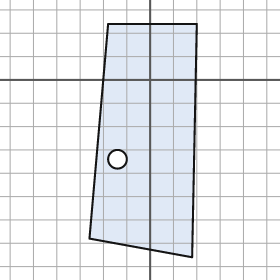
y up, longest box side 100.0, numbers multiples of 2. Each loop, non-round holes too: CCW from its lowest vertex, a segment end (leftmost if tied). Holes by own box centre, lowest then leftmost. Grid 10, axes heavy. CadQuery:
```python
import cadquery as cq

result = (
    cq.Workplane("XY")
    .moveTo(18.0, -76.0)
    .lineTo(20.0, 24.0)
    .lineTo(-18.0, 24.0)
    .lineTo(-26.0, -68.0)
    .close()
    .moveTo(-14.0, -34.0)
    .circle(4.0)
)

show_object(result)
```